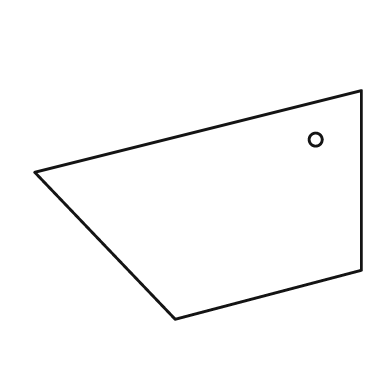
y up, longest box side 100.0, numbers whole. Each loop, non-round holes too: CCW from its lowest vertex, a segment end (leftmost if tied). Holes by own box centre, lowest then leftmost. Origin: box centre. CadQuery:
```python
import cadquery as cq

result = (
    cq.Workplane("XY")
    .moveTo(-7.0, -35.0)
    .lineTo(50.0, -20.0)
    .lineTo(50.0, 35.0)
    .lineTo(-50.0, 10.0)
    .close()
    .moveTo(36.0, 20.0)
    .circle(2.0)
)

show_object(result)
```